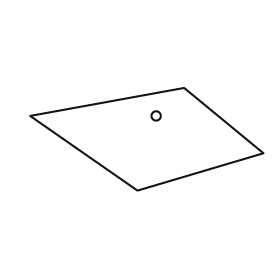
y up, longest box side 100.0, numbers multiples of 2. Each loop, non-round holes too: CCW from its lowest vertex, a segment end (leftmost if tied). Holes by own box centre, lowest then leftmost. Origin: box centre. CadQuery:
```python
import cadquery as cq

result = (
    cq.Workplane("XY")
    .moveTo(-4.0, -22.0)
    .lineTo(50.0, -6.0)
    .lineTo(16.0, 22.0)
    .lineTo(-50.0, 10.0)
    .close()
    .moveTo(4.0, 10.0)
    .circle(2.0)
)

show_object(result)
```